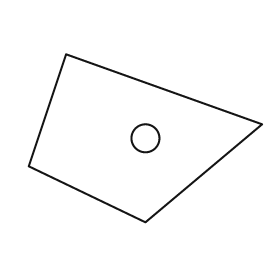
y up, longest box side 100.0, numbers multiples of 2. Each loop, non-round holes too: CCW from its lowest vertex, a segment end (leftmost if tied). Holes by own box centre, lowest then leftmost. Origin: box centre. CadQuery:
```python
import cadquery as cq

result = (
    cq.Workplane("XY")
    .moveTo(0.0, -36.0)
    .lineTo(50.0, 6.0)
    .lineTo(-34.0, 36.0)
    .lineTo(-50.0, -12.0)
    .close()
    .moveTo(0.0, 0.0)
    .circle(6.0)
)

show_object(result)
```